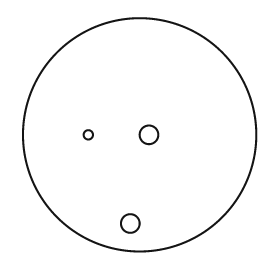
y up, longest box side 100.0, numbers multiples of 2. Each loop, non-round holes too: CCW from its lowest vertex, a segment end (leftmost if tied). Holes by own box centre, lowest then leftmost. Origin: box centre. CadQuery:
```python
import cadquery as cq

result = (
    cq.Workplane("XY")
    .moveTo(0.0, 0.0)
    .circle(50.0)
    .moveTo(-4.0, -38.0)
    .circle(4.0)
    .moveTo(-22.0, 0.0)
    .circle(2.0)
    .moveTo(4.0, 0.0)
    .circle(4.0)
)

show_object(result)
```